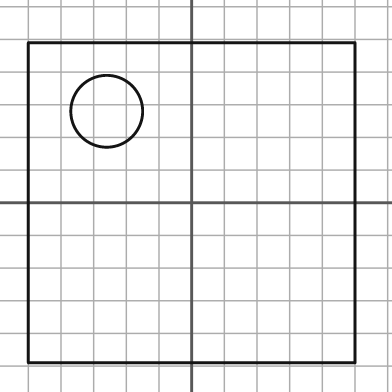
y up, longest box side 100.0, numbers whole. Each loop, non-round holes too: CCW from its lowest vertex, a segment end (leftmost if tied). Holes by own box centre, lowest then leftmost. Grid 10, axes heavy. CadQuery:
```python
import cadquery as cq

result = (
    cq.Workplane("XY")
    .moveTo(-50.0, -49.0)
    .lineTo(50.0, -49.0)
    .lineTo(50.0, 49.0)
    .lineTo(-50.0, 49.0)
    .close()
    .moveTo(-26.0, 28.0)
    .circle(11.0)
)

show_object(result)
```